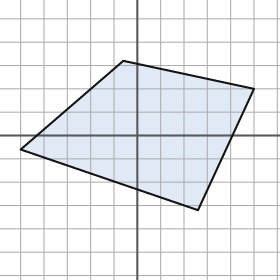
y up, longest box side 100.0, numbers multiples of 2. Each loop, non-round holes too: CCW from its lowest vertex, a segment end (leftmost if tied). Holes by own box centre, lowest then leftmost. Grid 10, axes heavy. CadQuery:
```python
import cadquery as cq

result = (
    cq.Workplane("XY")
    .moveTo(26.0, -32.0)
    .lineTo(50.0, 20.0)
    .lineTo(-6.0, 32.0)
    .lineTo(-50.0, -6.0)
    .close()
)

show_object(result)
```